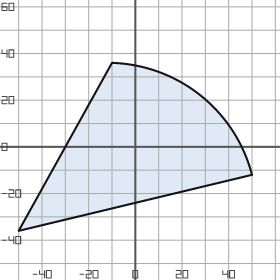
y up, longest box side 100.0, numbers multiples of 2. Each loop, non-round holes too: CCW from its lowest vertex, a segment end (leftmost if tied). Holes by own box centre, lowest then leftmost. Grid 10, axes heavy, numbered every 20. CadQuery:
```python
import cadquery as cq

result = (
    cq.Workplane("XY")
    .moveTo(-50.0, -36.0)
    .lineTo(50.0, -12.0)
    .threePointArc((28.0, 22.0), (-10.0, 36.0))
    .close()
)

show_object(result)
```